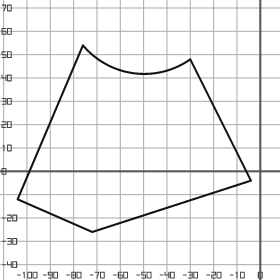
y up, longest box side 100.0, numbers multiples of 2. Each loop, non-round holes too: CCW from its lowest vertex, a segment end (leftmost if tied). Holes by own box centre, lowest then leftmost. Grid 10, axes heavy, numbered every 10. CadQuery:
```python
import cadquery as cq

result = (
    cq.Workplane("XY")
    .moveTo(-72.0, -26.0)
    .lineTo(-4.0, -4.0)
    .lineTo(-30.0, 48.0)
    .threePointArc((-54.0, 42.0), (-76.0, 54.0))
    .lineTo(-104.0, -12.0)
    .close()
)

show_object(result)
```